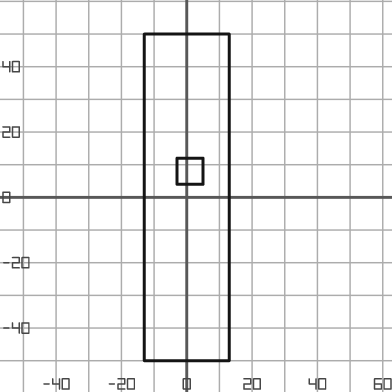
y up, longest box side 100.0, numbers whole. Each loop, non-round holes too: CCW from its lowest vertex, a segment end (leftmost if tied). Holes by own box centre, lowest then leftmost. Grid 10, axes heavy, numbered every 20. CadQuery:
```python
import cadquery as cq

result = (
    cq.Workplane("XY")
    .moveTo(-13.0, -50.0)
    .lineTo(13.0, -50.0)
    .lineTo(13.0, 50.0)
    .lineTo(-13.0, 50.0)
    .close()
    .moveTo(-3.0, 4.0)
    .lineTo(5.0, 4.0)
    .lineTo(5.0, 12.0)
    .lineTo(-3.0, 12.0)
    .close()
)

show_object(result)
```